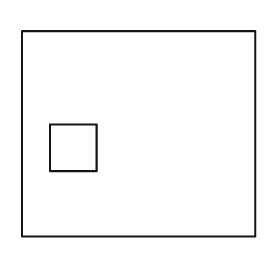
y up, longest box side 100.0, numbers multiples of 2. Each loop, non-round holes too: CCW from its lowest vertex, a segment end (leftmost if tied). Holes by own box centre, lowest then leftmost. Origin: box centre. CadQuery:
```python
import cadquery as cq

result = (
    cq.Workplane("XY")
    .moveTo(-50.0, -44.0)
    .lineTo(50.0, -44.0)
    .lineTo(50.0, 44.0)
    .lineTo(-50.0, 44.0)
    .close()
    .moveTo(-38.0, -16.0)
    .lineTo(-18.0, -16.0)
    .lineTo(-18.0, 4.0)
    .lineTo(-38.0, 4.0)
    .close()
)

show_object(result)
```